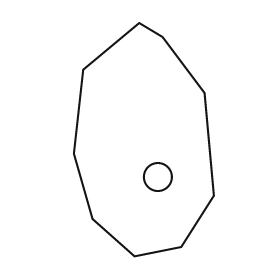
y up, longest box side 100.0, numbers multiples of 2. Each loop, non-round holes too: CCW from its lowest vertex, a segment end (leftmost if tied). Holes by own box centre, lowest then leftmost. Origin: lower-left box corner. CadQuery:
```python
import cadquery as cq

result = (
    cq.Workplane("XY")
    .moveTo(26.0, 0.0)
    .lineTo(46.0, 4.0)
    .lineTo(60.0, 26.0)
    .lineTo(56.0, 70.0)
    .lineTo(38.0, 94.0)
    .lineTo(28.0, 100.0)
    .lineTo(4.0, 80.0)
    .lineTo(0.0, 44.0)
    .lineTo(8.0, 16.0)
    .close()
    .moveTo(36.0, 34.0)
    .circle(6.0)
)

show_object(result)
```